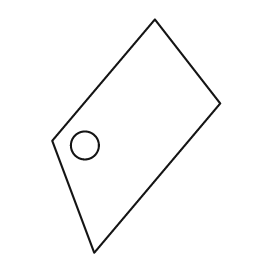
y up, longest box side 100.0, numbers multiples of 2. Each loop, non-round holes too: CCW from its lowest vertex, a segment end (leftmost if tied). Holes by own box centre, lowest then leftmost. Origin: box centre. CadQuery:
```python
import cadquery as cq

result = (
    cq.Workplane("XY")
    .moveTo(-18.0, -50.0)
    .lineTo(36.0, 14.0)
    .lineTo(8.0, 50.0)
    .lineTo(-36.0, -2.0)
    .close()
    .moveTo(-22.0, -4.0)
    .circle(6.0)
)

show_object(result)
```